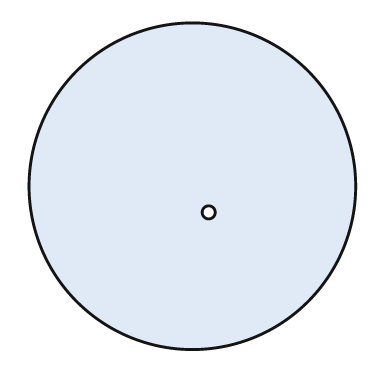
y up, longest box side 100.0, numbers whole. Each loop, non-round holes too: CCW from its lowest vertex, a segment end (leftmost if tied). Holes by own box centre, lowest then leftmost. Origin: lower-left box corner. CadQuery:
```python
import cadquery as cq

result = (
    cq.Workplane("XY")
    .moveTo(50.0, 50.0)
    .circle(50.0)
    .moveTo(55.0, 42.0)
    .circle(2.0)
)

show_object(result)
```